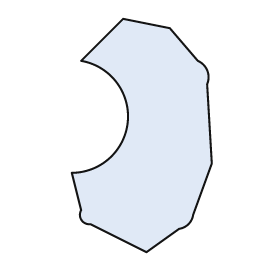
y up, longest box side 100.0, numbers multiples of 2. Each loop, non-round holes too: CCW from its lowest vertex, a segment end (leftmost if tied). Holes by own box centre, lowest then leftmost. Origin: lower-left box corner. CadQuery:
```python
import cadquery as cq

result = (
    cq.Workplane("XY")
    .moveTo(32.0, 0.0)
    .lineTo(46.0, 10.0)
    .threePointArc((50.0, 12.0), (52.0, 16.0))
    .lineTo(60.0, 38.0)
    .lineTo(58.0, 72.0)
    .threePointArc((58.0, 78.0), (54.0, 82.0))
    .lineTo(42.0, 96.0)
    .lineTo(22.0, 100.0)
    .lineTo(4.0, 82.0)
    .threePointArc((24.0, 56.0), (0.0, 34.0))
    .lineTo(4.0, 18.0)
    .threePointArc((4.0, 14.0), (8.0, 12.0))
    .close()
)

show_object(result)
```